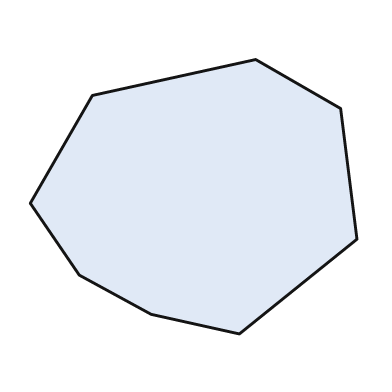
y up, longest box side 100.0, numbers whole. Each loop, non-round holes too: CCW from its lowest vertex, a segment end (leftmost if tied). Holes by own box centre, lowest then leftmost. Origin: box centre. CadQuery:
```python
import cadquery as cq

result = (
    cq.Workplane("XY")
    .moveTo(14.0, -42.0)
    .lineTo(50.0, -13.0)
    .lineTo(45.0, 27.0)
    .lineTo(19.0, 42.0)
    .lineTo(-31.0, 31.0)
    .lineTo(-50.0, -2.0)
    .lineTo(-35.0, -24.0)
    .lineTo(-13.0, -36.0)
    .close()
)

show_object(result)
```